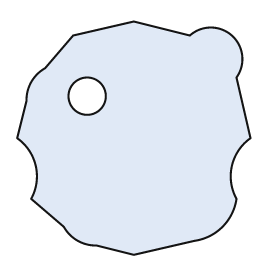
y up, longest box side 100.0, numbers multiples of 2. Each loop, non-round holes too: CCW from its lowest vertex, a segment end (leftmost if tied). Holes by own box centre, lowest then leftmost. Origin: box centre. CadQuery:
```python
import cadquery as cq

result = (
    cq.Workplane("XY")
    .moveTo(0.0, -50.0)
    .lineTo(26.0, -44.0)
    .threePointArc((38.0, -38.0), (44.0, -26.0))
    .threePointArc((42.0, -12.0), (50.0, 0.0))
    .lineTo(44.0, 26.0)
    .threePointArc((42.0, 44.0), (24.0, 44.0))
    .lineTo(0.0, 50.0)
    .lineTo(-26.0, 44.0)
    .lineTo(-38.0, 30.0)
    .threePointArc((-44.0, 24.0), (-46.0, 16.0))
    .lineTo(-50.0, 0.0)
    .threePointArc((-42.0, -12.0), (-44.0, -26.0))
    .lineTo(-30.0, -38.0)
    .threePointArc((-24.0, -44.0), (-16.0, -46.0))
    .close()
    .moveTo(-20.0, 18.0)
    .circle(8.0)
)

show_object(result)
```